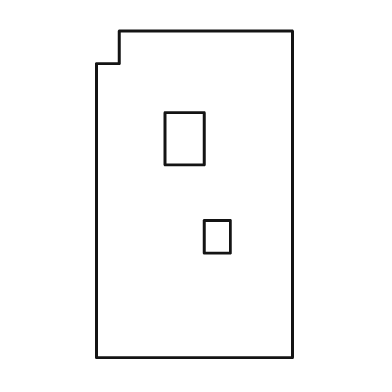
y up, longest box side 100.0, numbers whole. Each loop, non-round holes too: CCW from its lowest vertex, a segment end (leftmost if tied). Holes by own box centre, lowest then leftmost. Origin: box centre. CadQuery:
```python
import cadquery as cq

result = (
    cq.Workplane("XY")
    .moveTo(-30.0, -50.0)
    .lineTo(30.0, -50.0)
    .lineTo(30.0, 50.0)
    .lineTo(-23.0, 50.0)
    .lineTo(-23.0, 40.0)
    .lineTo(-30.0, 40.0)
    .close()
    .moveTo(3.0, -18.0)
    .lineTo(11.0, -18.0)
    .lineTo(11.0, -8.0)
    .lineTo(3.0, -8.0)
    .close()
    .moveTo(-9.0, 9.0)
    .lineTo(3.0, 9.0)
    .lineTo(3.0, 25.0)
    .lineTo(-9.0, 25.0)
    .close()
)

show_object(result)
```